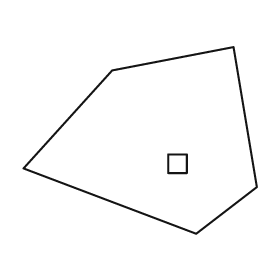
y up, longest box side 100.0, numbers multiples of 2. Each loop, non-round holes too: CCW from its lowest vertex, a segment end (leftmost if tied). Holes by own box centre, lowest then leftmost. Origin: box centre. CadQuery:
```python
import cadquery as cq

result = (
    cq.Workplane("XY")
    .moveTo(24.0, -40.0)
    .lineTo(50.0, -20.0)
    .lineTo(40.0, 40.0)
    .lineTo(-12.0, 30.0)
    .lineTo(-50.0, -12.0)
    .close()
    .moveTo(12.0, -14.0)
    .lineTo(20.0, -14.0)
    .lineTo(20.0, -6.0)
    .lineTo(12.0, -6.0)
    .close()
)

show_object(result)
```